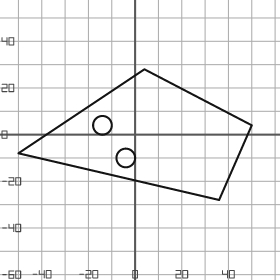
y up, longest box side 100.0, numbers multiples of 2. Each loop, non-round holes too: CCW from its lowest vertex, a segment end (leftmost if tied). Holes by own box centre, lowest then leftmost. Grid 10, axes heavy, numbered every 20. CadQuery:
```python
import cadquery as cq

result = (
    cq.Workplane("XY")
    .moveTo(36.0, -28.0)
    .lineTo(50.0, 4.0)
    .lineTo(4.0, 28.0)
    .lineTo(-50.0, -8.0)
    .close()
    .moveTo(-4.0, -10.0)
    .circle(4.0)
    .moveTo(-14.0, 4.0)
    .circle(4.0)
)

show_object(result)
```